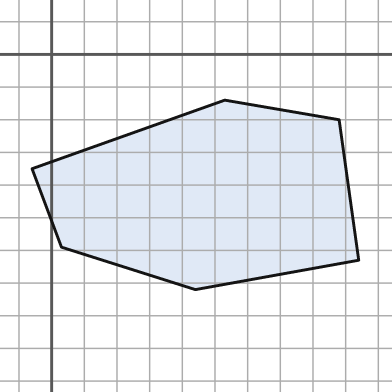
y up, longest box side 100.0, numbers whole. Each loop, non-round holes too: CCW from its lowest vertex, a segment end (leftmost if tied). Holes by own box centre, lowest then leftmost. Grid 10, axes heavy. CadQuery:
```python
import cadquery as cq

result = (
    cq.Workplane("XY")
    .moveTo(44.0, -72.0)
    .lineTo(94.0, -63.0)
    .lineTo(88.0, -20.0)
    .lineTo(53.0, -14.0)
    .lineTo(-6.0, -35.0)
    .lineTo(3.0, -59.0)
    .close()
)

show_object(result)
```